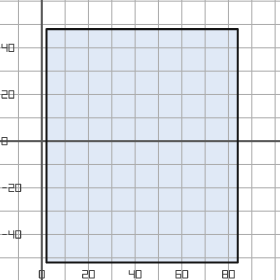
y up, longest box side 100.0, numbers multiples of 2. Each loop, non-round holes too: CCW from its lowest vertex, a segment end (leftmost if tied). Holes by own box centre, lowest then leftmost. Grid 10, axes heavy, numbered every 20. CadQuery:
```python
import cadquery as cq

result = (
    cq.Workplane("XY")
    .moveTo(2.0, -52.0)
    .lineTo(84.0, -52.0)
    .lineTo(84.0, 48.0)
    .lineTo(2.0, 48.0)
    .close()
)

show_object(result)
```